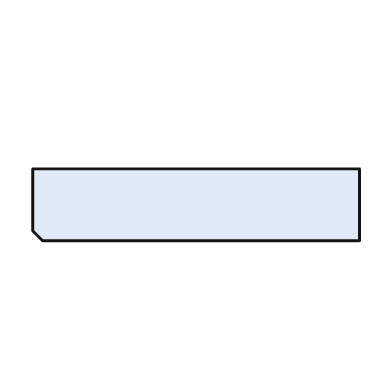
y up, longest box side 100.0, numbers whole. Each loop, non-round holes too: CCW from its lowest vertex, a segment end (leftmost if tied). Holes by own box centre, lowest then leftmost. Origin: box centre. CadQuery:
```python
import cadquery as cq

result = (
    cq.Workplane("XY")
    .moveTo(-47.0, -11.0)
    .lineTo(50.0, -11.0)
    .lineTo(50.0, 11.0)
    .lineTo(-50.0, 11.0)
    .lineTo(-50.0, -8.0)
    .close()
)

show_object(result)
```